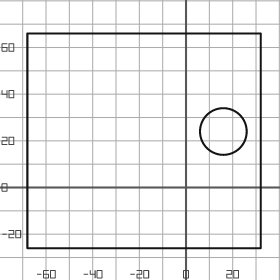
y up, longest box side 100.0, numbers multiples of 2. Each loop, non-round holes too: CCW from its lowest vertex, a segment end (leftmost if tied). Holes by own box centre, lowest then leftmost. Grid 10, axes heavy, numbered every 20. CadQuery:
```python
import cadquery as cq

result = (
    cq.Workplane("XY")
    .moveTo(-68.0, -26.0)
    .lineTo(32.0, -26.0)
    .lineTo(32.0, 66.0)
    .lineTo(-68.0, 66.0)
    .close()
    .moveTo(16.0, 24.0)
    .circle(10.0)
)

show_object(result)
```